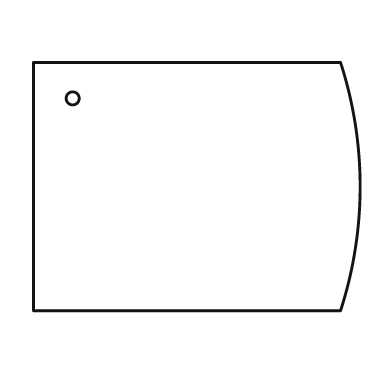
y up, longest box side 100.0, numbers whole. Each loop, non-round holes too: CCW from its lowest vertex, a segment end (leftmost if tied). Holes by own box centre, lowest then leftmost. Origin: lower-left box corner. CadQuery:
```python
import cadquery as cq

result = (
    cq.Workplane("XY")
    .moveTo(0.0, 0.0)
    .lineTo(94.0, 0.0)
    .threePointArc((100.0, 38.0), (94.0, 76.0))
    .lineTo(0.0, 76.0)
    .close()
    .moveTo(12.0, 65.0)
    .circle(2.0)
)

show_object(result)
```